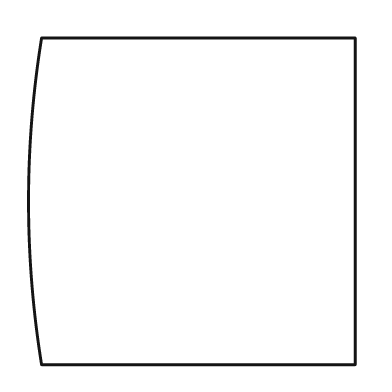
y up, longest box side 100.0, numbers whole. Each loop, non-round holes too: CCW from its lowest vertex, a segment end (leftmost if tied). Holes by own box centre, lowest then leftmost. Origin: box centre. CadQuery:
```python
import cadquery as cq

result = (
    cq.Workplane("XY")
    .moveTo(-46.0, -50.0)
    .lineTo(50.0, -50.0)
    .lineTo(50.0, 50.0)
    .lineTo(-46.0, 50.0)
    .threePointArc((-50.0, 0.0), (-46.0, -50.0))
    .close()
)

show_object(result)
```